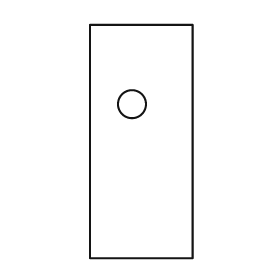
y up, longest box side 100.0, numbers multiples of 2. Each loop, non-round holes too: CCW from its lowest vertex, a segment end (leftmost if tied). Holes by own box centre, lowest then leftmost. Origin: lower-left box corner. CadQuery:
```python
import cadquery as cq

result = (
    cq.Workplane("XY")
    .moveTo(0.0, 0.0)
    .lineTo(44.0, 0.0)
    .lineTo(44.0, 100.0)
    .lineTo(0.0, 100.0)
    .close()
    .moveTo(18.0, 66.0)
    .circle(6.0)
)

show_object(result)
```